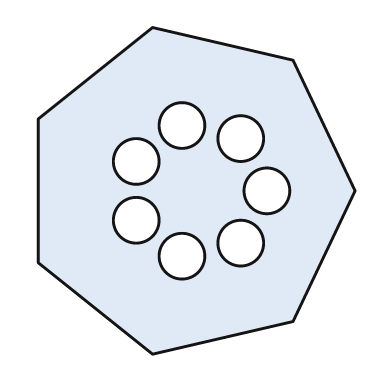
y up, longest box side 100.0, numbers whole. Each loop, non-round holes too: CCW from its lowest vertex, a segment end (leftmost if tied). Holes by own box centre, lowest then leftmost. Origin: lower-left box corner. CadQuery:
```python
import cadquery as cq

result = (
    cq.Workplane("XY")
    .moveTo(35.0, 0.0)
    .lineTo(78.0, 10.0)
    .lineTo(97.0, 50.0)
    .lineTo(78.0, 90.0)
    .lineTo(35.0, 100.0)
    .lineTo(0.0, 72.0)
    .lineTo(0.0, 28.0)
    .close()
    .moveTo(44.0, 30.0)
    .circle(7.0)
    .moveTo(62.0, 34.0)
    .circle(7.0)
    .moveTo(30.0, 41.0)
    .circle(7.0)
    .moveTo(70.0, 50.0)
    .circle(7.0)
    .moveTo(30.0, 59.0)
    .circle(7.0)
    .moveTo(62.0, 66.0)
    .circle(7.0)
    .moveTo(44.0, 70.0)
    .circle(7.0)
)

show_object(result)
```